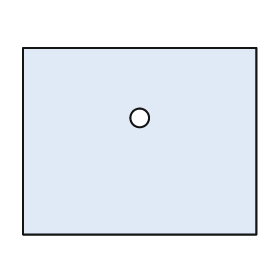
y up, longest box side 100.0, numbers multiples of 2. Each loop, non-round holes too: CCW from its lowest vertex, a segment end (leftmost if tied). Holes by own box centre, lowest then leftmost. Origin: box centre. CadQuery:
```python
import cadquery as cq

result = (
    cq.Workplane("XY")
    .moveTo(-50.0, -40.0)
    .lineTo(50.0, -40.0)
    .lineTo(50.0, 40.0)
    .lineTo(-50.0, 40.0)
    .close()
    .moveTo(0.0, 10.0)
    .circle(4.0)
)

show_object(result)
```